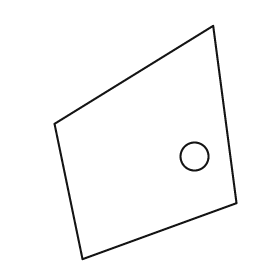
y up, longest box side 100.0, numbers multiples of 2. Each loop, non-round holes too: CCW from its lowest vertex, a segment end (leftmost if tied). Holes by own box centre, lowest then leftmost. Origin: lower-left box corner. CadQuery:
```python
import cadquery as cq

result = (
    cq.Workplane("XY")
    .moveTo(12.0, 0.0)
    .lineTo(78.0, 24.0)
    .lineTo(68.0, 100.0)
    .lineTo(0.0, 58.0)
    .close()
    .moveTo(60.0, 44.0)
    .circle(6.0)
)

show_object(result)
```